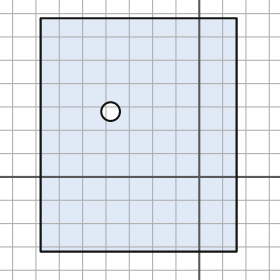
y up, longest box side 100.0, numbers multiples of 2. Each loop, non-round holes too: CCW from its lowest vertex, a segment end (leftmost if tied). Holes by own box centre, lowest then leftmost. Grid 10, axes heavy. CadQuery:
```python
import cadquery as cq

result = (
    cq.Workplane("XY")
    .moveTo(-68.0, -32.0)
    .lineTo(16.0, -32.0)
    .lineTo(16.0, 68.0)
    .lineTo(-68.0, 68.0)
    .close()
    .moveTo(-38.0, 28.0)
    .circle(4.0)
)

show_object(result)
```